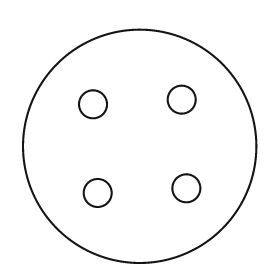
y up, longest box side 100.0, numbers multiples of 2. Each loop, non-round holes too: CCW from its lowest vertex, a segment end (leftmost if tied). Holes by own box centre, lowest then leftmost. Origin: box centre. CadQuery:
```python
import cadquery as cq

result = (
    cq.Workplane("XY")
    .moveTo(0.0, 0.0)
    .circle(50.0)
    .moveTo(-18.0, -20.0)
    .circle(6.0)
    .moveTo(20.0, -18.0)
    .circle(6.0)
    .moveTo(-20.0, 18.0)
    .circle(6.0)
    .moveTo(18.0, 20.0)
    .circle(6.0)
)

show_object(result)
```